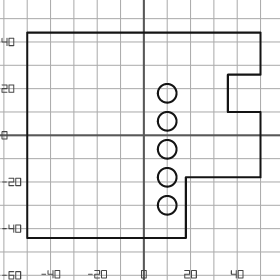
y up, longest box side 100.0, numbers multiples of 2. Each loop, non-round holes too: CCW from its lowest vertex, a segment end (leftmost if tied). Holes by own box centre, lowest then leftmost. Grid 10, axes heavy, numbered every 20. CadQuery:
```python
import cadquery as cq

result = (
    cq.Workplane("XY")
    .moveTo(-50.0, -44.0)
    .lineTo(18.0, -44.0)
    .lineTo(18.0, -18.0)
    .lineTo(50.0, -18.0)
    .lineTo(50.0, 10.0)
    .lineTo(36.0, 10.0)
    .lineTo(36.0, 26.0)
    .lineTo(50.0, 26.0)
    .lineTo(50.0, 44.0)
    .lineTo(-50.0, 44.0)
    .close()
    .moveTo(10.0, -30.0)
    .circle(4.0)
    .moveTo(10.0, -18.0)
    .circle(4.0)
    .moveTo(10.0, -6.0)
    .circle(4.0)
    .moveTo(10.0, 6.0)
    .circle(4.0)
    .moveTo(10.0, 18.0)
    .circle(4.0)
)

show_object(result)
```